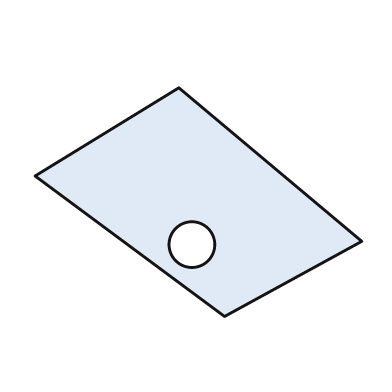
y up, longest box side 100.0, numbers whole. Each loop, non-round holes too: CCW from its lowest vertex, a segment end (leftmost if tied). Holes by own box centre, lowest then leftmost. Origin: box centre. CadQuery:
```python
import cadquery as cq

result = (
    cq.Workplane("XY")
    .moveTo(8.0, -35.0)
    .lineTo(50.0, -12.0)
    .lineTo(-6.0, 35.0)
    .lineTo(-50.0, 8.0)
    .close()
    .moveTo(-2.0, -13.0)
    .circle(7.0)
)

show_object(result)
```